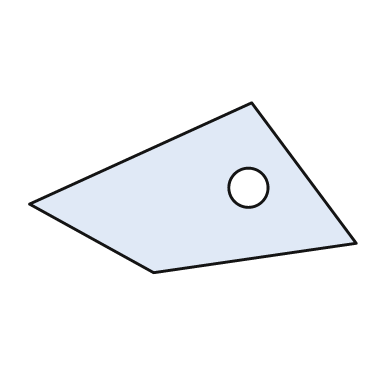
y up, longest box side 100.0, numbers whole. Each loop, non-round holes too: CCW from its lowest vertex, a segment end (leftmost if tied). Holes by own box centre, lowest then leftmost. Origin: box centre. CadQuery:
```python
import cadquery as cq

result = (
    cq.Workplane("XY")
    .moveTo(-12.0, -26.0)
    .lineTo(50.0, -17.0)
    .lineTo(18.0, 26.0)
    .lineTo(-50.0, -5.0)
    .close()
    .moveTo(17.0, 0.0)
    .circle(6.0)
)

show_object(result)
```